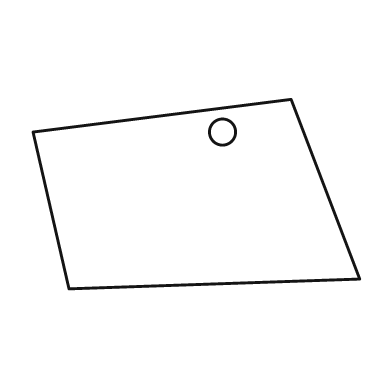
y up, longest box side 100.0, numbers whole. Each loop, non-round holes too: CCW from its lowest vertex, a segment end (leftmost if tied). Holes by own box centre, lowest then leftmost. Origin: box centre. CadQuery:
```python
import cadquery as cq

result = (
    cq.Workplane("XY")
    .moveTo(-39.0, -29.0)
    .lineTo(50.0, -26.0)
    .lineTo(29.0, 29.0)
    .lineTo(-50.0, 19.0)
    .close()
    .moveTo(8.0, 19.0)
    .circle(4.0)
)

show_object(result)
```